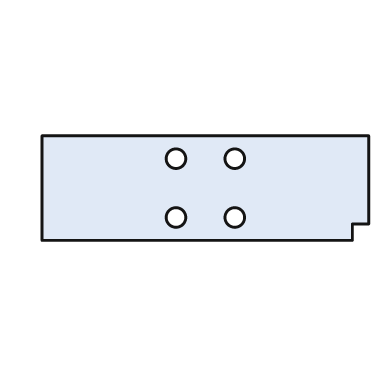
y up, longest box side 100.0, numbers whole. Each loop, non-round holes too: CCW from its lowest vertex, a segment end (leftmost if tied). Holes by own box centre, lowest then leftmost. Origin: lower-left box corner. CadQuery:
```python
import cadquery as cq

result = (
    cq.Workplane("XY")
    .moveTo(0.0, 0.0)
    .lineTo(95.0, 0.0)
    .lineTo(95.0, 5.0)
    .lineTo(100.0, 5.0)
    .lineTo(100.0, 32.0)
    .lineTo(0.0, 32.0)
    .close()
    .moveTo(41.0, 7.0)
    .circle(3.0)
    .moveTo(59.0, 7.0)
    .circle(3.0)
    .moveTo(41.0, 25.0)
    .circle(3.0)
    .moveTo(59.0, 25.0)
    .circle(3.0)
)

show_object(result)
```